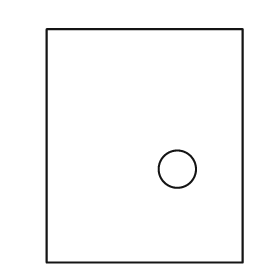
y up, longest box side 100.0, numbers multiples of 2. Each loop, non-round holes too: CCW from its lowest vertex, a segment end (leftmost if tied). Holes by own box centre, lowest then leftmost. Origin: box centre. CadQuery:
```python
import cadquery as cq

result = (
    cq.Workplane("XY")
    .moveTo(-42.0, -50.0)
    .lineTo(42.0, -50.0)
    .lineTo(42.0, 50.0)
    .lineTo(-42.0, 50.0)
    .close()
    .moveTo(14.0, -10.0)
    .circle(8.0)
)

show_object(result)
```